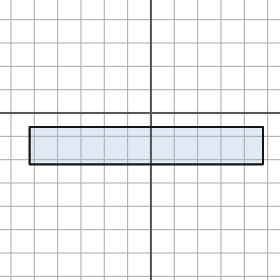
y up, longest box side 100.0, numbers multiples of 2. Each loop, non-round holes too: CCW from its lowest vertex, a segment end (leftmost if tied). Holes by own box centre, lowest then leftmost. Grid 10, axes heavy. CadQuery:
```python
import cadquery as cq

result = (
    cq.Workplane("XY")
    .moveTo(-52.0, -22.0)
    .lineTo(48.0, -22.0)
    .lineTo(48.0, -6.0)
    .lineTo(-52.0, -6.0)
    .close()
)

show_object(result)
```